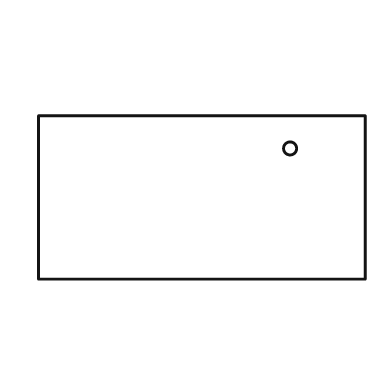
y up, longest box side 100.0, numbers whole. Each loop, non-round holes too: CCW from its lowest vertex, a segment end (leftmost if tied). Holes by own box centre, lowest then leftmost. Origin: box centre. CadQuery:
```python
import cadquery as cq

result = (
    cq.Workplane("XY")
    .moveTo(-50.0, -25.0)
    .lineTo(50.0, -25.0)
    .lineTo(50.0, 25.0)
    .lineTo(-50.0, 25.0)
    .close()
    .moveTo(27.0, 15.0)
    .circle(2.0)
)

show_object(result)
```